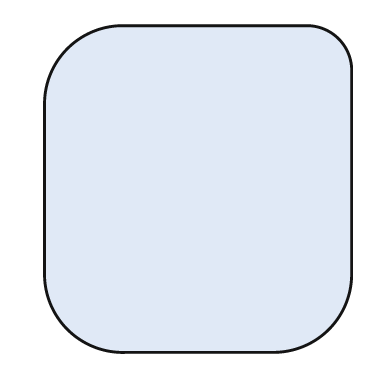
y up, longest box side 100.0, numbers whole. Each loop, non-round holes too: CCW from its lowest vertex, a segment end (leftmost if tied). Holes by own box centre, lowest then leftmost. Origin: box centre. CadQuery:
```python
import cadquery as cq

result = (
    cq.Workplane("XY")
    .moveTo(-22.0, -50.0)
    .lineTo(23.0, -50.0)
    .threePointArc((40.0, -43.0), (47.0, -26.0))
    .lineTo(47.0, 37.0)
    .threePointArc((43.0, 46.0), (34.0, 50.0))
    .lineTo(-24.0, 50.0)
    .threePointArc((-40.0, 43.0), (-47.0, 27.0))
    .lineTo(-47.0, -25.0)
    .threePointArc((-40.0, -43.0), (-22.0, -50.0))
    .close()
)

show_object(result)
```